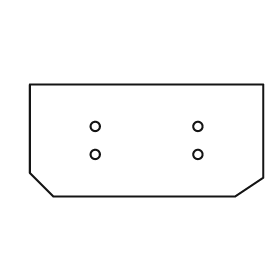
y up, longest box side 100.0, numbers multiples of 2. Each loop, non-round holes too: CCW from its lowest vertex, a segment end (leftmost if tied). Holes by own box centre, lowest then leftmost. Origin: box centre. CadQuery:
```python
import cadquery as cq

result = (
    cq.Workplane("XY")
    .moveTo(-40.0, -24.0)
    .lineTo(38.0, -24.0)
    .lineTo(50.0, -16.0)
    .lineTo(50.0, 24.0)
    .lineTo(-50.0, 24.0)
    .lineTo(-50.0, -14.0)
    .close()
    .moveTo(-22.0, -6.0)
    .circle(2.0)
    .moveTo(22.0, -6.0)
    .circle(2.0)
    .moveTo(-22.0, 6.0)
    .circle(2.0)
    .moveTo(22.0, 6.0)
    .circle(2.0)
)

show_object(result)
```